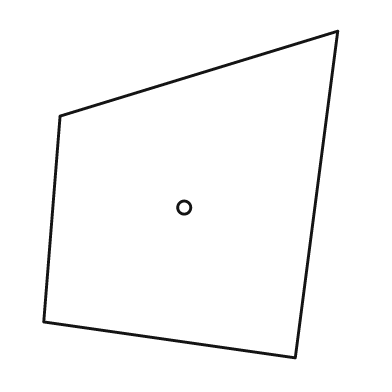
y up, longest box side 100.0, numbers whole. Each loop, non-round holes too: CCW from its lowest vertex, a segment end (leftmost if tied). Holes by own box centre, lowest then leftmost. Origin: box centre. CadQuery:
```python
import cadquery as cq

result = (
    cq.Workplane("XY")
    .moveTo(32.0, -50.0)
    .lineTo(45.0, 50.0)
    .lineTo(-40.0, 24.0)
    .lineTo(-45.0, -39.0)
    .close()
    .moveTo(-2.0, -4.0)
    .circle(2.0)
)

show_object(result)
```